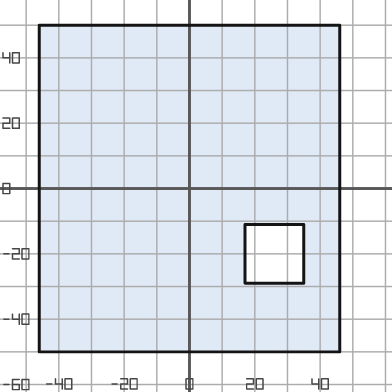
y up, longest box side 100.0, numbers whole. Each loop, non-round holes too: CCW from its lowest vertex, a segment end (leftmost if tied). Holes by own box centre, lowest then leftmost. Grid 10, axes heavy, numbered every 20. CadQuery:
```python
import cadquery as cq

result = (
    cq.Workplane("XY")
    .moveTo(-46.0, -50.0)
    .lineTo(46.0, -50.0)
    .lineTo(46.0, 50.0)
    .lineTo(-46.0, 50.0)
    .close()
    .moveTo(17.0, -29.0)
    .lineTo(35.0, -29.0)
    .lineTo(35.0, -11.0)
    .lineTo(17.0, -11.0)
    .close()
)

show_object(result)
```